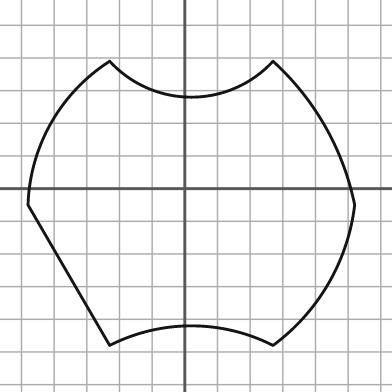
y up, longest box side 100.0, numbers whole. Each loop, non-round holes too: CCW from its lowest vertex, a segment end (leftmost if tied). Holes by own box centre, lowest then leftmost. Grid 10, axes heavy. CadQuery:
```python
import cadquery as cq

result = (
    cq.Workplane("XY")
    .moveTo(-23.0, -48.0)
    .threePointArc((2.0, -42.0), (27.0, -48.0))
    .threePointArc((44.0, -29.0), (52.0, -5.0))
    .threePointArc((43.0, 19.0), (27.0, 39.0))
    .threePointArc((2.0, 28.0), (-23.0, 39.0))
    .threePointArc((-41.0, 20.0), (-48.0, -5.0))
    .close()
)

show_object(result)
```